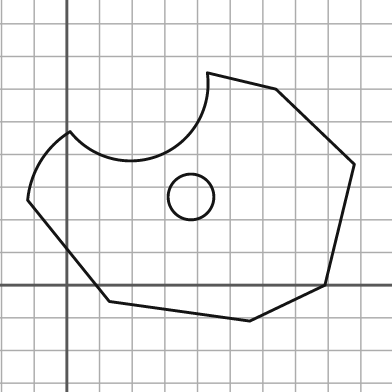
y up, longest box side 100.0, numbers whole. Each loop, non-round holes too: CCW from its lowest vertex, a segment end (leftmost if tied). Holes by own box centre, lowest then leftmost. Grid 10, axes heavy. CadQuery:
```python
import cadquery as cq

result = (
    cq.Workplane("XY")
    .moveTo(56.0, -11.0)
    .lineTo(79.0, 0.0)
    .lineTo(88.0, 37.0)
    .lineTo(64.0, 60.0)
    .lineTo(43.0, 65.0)
    .threePointArc((29.0, 40.0), (1.0, 47.0))
    .threePointArc((-8.0, 38.0), (-12.0, 26.0))
    .lineTo(13.0, -5.0)
    .close()
    .moveTo(38.0, 27.0)
    .circle(7.0)
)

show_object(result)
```